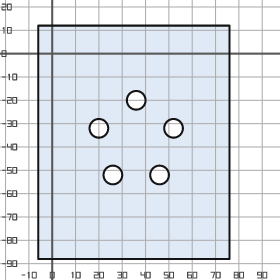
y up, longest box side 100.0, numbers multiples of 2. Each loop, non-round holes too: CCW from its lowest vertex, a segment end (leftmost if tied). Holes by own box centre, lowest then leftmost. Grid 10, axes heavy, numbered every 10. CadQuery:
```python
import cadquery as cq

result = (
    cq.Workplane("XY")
    .moveTo(-6.0, -88.0)
    .lineTo(76.0, -88.0)
    .lineTo(76.0, 12.0)
    .lineTo(-6.0, 12.0)
    .close()
    .moveTo(26.0, -52.0)
    .circle(4.0)
    .moveTo(46.0, -52.0)
    .circle(4.0)
    .moveTo(20.0, -32.0)
    .circle(4.0)
    .moveTo(52.0, -32.0)
    .circle(4.0)
    .moveTo(36.0, -20.0)
    .circle(4.0)
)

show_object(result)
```